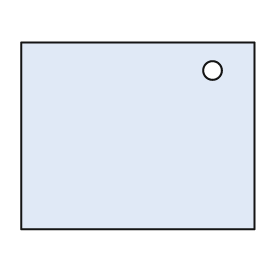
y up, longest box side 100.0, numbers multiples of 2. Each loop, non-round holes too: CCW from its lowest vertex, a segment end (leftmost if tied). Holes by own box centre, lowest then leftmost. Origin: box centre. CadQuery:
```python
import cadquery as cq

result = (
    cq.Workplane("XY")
    .moveTo(-50.0, -40.0)
    .lineTo(50.0, -40.0)
    .lineTo(50.0, 40.0)
    .lineTo(-50.0, 40.0)
    .close()
    .moveTo(32.0, 28.0)
    .circle(4.0)
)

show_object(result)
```